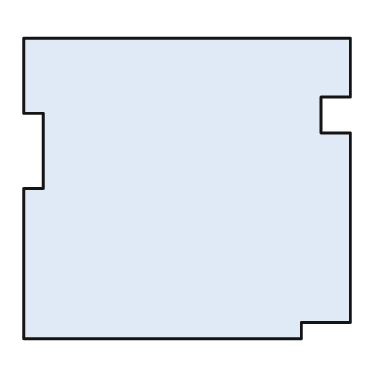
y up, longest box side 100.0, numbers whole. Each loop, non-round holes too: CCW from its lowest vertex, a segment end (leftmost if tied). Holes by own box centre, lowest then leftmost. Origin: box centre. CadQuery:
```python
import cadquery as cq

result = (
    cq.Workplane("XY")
    .moveTo(-50.0, -46.0)
    .lineTo(35.0, -46.0)
    .lineTo(35.0, -41.0)
    .lineTo(50.0, -41.0)
    .lineTo(50.0, 17.0)
    .lineTo(41.0, 17.0)
    .lineTo(41.0, 28.0)
    .lineTo(50.0, 28.0)
    .lineTo(50.0, 46.0)
    .lineTo(-50.0, 46.0)
    .lineTo(-50.0, 23.0)
    .lineTo(-44.0, 23.0)
    .lineTo(-44.0, 0.0)
    .lineTo(-50.0, 0.0)
    .close()
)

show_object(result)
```